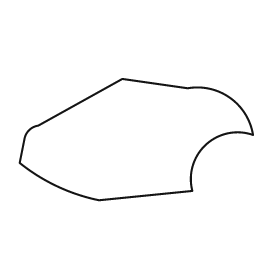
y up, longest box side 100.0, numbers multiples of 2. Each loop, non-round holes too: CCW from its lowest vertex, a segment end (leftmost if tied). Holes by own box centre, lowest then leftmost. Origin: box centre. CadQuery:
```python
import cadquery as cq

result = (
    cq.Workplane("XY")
    .moveTo(-16.0, -26.0)
    .lineTo(24.0, -22.0)
    .threePointArc((30.0, -2.0), (50.0, 2.0))
    .threePointArc((40.0, 18.0), (22.0, 22.0))
    .lineTo(-6.0, 26.0)
    .lineTo(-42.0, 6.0)
    .threePointArc((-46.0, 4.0), (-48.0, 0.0))
    .lineTo(-50.0, -10.0)
    .threePointArc((-34.0, -20.0), (-16.0, -26.0))
    .close()
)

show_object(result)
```